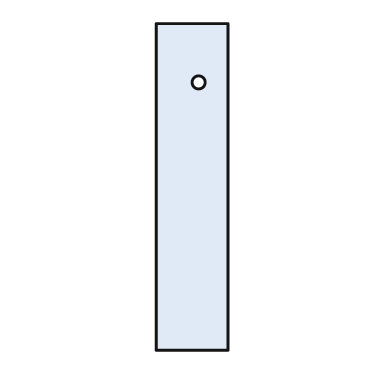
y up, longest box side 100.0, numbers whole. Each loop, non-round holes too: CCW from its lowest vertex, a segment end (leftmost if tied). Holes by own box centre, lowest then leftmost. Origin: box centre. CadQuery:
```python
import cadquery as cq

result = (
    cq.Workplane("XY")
    .moveTo(-11.0, -50.0)
    .lineTo(11.0, -50.0)
    .lineTo(11.0, 50.0)
    .lineTo(-11.0, 50.0)
    .close()
    .moveTo(2.0, 32.0)
    .circle(2.0)
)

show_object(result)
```